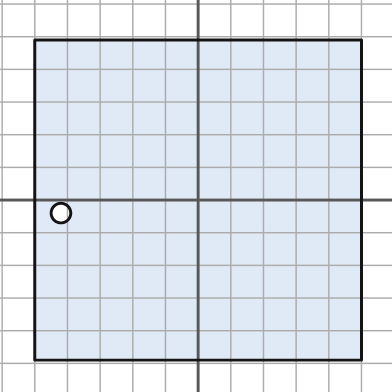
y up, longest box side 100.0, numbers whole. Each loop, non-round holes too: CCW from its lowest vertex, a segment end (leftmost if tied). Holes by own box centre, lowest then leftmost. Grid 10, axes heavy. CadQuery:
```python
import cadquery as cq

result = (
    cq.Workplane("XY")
    .moveTo(-50.0, -49.0)
    .lineTo(50.0, -49.0)
    .lineTo(50.0, 49.0)
    .lineTo(-50.0, 49.0)
    .close()
    .moveTo(-42.0, -4.0)
    .circle(3.0)
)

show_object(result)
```